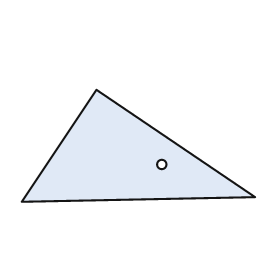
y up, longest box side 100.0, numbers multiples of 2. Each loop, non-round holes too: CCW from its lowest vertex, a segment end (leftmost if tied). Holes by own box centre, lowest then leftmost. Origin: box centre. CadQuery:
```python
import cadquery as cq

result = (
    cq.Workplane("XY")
    .moveTo(-50.0, -24.0)
    .lineTo(50.0, -22.0)
    .lineTo(-18.0, 24.0)
    .close()
    .moveTo(10.0, -8.0)
    .circle(2.0)
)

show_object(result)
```